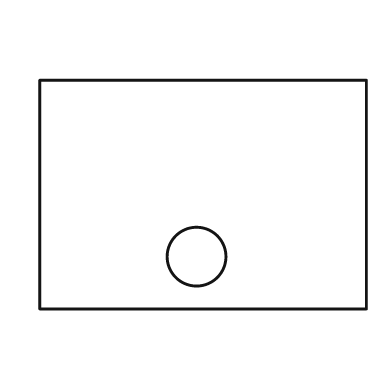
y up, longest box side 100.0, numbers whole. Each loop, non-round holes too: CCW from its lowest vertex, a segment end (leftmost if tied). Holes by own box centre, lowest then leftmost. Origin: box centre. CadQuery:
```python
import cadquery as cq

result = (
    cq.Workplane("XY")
    .moveTo(-50.0, -35.0)
    .lineTo(50.0, -35.0)
    .lineTo(50.0, 35.0)
    .lineTo(-50.0, 35.0)
    .close()
    .moveTo(-2.0, -19.0)
    .circle(9.0)
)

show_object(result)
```